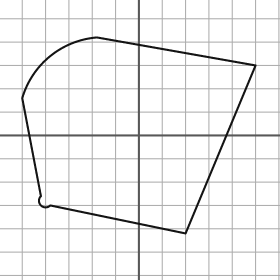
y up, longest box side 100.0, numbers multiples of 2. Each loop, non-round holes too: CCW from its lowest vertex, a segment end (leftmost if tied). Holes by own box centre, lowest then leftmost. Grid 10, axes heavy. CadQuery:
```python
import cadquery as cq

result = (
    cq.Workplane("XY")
    .moveTo(20.0, -42.0)
    .lineTo(50.0, 30.0)
    .lineTo(-18.0, 42.0)
    .threePointArc((-38.0, 34.0), (-50.0, 16.0))
    .lineTo(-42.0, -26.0)
    .threePointArc((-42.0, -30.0), (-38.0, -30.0))
    .close()
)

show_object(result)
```